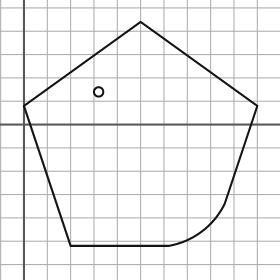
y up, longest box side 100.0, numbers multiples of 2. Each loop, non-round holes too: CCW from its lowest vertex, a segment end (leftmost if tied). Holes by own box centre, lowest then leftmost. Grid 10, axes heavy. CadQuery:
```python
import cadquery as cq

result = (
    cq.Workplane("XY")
    .moveTo(20.0, -52.0)
    .lineTo(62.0, -52.0)
    .threePointArc((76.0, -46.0), (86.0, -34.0))
    .lineTo(100.0, 8.0)
    .lineTo(50.0, 44.0)
    .lineTo(0.0, 8.0)
    .close()
    .moveTo(32.0, 14.0)
    .circle(2.0)
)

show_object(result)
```